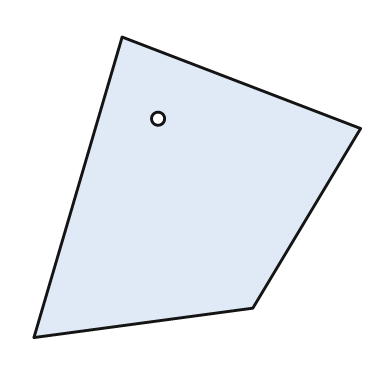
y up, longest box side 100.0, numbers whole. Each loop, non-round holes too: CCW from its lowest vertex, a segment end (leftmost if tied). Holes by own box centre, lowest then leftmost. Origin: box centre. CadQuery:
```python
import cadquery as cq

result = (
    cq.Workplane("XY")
    .moveTo(-50.0, -46.0)
    .lineTo(17.0, -37.0)
    .lineTo(50.0, 18.0)
    .lineTo(-23.0, 46.0)
    .close()
    .moveTo(-12.0, 21.0)
    .circle(2.0)
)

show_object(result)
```